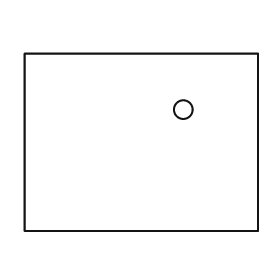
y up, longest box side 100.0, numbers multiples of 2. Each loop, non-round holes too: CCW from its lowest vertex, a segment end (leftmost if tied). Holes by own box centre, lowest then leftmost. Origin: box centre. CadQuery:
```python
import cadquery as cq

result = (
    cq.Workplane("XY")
    .moveTo(-50.0, -38.0)
    .lineTo(50.0, -38.0)
    .lineTo(50.0, 38.0)
    .lineTo(-50.0, 38.0)
    .close()
    .moveTo(18.0, 14.0)
    .circle(4.0)
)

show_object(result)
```